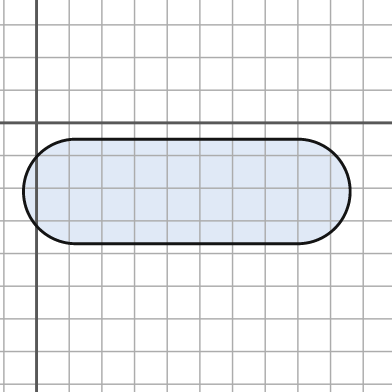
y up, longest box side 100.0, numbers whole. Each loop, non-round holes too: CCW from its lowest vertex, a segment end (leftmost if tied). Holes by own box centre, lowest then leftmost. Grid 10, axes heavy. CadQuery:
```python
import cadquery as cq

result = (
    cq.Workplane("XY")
    .moveTo(12.0, -37.0)
    .lineTo(80.0, -37.0)
    .threePointArc((96.0, -21.0), (80.0, -5.0))
    .lineTo(12.0, -5.0)
    .threePointArc((-4.0, -21.0), (12.0, -37.0))
    .close()
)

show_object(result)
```